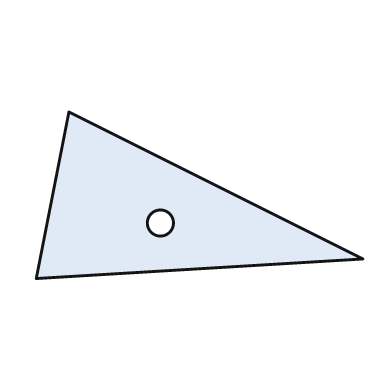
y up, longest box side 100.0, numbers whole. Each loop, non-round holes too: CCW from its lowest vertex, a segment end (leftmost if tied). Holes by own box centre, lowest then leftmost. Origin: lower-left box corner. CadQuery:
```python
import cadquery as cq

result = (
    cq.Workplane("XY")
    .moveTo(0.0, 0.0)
    .lineTo(100.0, 6.0)
    .lineTo(10.0, 51.0)
    .close()
    .moveTo(38.0, 17.0)
    .circle(4.0)
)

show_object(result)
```